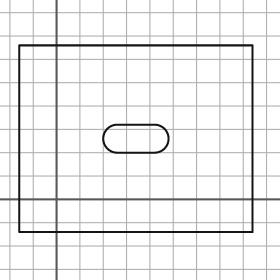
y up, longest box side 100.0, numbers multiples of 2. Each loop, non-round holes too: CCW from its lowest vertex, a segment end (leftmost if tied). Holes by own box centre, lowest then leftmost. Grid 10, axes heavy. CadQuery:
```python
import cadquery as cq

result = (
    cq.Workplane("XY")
    .moveTo(-16.0, -14.0)
    .lineTo(84.0, -14.0)
    .lineTo(84.0, 66.0)
    .lineTo(-16.0, 66.0)
    .close()
    .moveTo(26.0, 20.0)
    .lineTo(42.0, 20.0)
    .threePointArc((48.0, 26.0), (42.0, 32.0))
    .lineTo(26.0, 32.0)
    .threePointArc((20.0, 26.0), (26.0, 20.0))
    .close()
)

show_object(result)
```